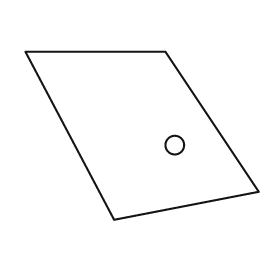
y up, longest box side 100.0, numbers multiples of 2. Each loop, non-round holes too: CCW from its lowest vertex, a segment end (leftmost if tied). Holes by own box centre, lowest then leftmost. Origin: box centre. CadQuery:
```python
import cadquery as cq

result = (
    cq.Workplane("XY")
    .moveTo(-12.0, -36.0)
    .lineTo(50.0, -24.0)
    .lineTo(10.0, 36.0)
    .lineTo(-50.0, 36.0)
    .close()
    .moveTo(14.0, -4.0)
    .circle(4.0)
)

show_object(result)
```